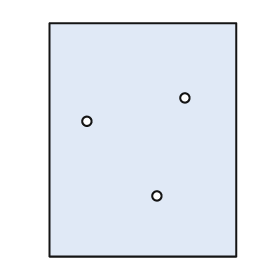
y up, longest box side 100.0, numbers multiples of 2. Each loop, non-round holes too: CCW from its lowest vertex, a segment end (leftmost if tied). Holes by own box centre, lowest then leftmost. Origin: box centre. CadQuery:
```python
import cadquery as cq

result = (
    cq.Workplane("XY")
    .moveTo(-40.0, -50.0)
    .lineTo(40.0, -50.0)
    .lineTo(40.0, 50.0)
    .lineTo(-40.0, 50.0)
    .close()
    .moveTo(6.0, -24.0)
    .circle(2.0)
    .moveTo(-24.0, 8.0)
    .circle(2.0)
    .moveTo(18.0, 18.0)
    .circle(2.0)
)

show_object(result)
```